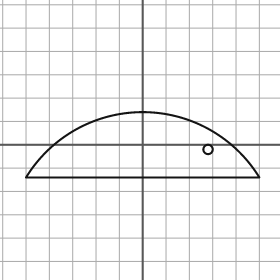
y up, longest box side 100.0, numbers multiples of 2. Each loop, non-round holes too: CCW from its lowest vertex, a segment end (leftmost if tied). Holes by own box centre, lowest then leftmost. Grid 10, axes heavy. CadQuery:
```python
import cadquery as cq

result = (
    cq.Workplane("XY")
    .moveTo(-50.0, -14.0)
    .lineTo(50.0, -14.0)
    .threePointArc((0.0, 14.0), (-50.0, -14.0))
    .close()
    .moveTo(28.0, -2.0)
    .circle(2.0)
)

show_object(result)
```